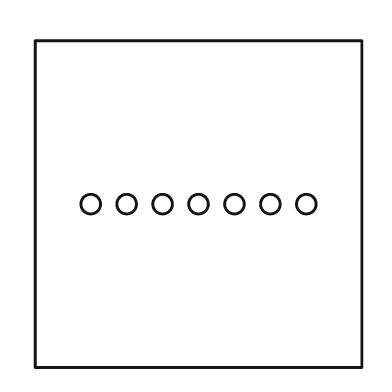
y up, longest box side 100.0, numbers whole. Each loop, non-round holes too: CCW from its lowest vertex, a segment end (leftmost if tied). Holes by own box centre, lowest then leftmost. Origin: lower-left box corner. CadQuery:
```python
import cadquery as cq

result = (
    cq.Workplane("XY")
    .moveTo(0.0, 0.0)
    .lineTo(100.0, 0.0)
    .lineTo(100.0, 100.0)
    .lineTo(0.0, 100.0)
    .close()
    .moveTo(17.0, 50.0)
    .circle(3.0)
    .moveTo(28.0, 50.0)
    .circle(3.0)
    .moveTo(39.0, 50.0)
    .circle(3.0)
    .moveTo(50.0, 50.0)
    .circle(3.0)
    .moveTo(61.0, 50.0)
    .circle(3.0)
    .moveTo(72.0, 50.0)
    .circle(3.0)
    .moveTo(83.0, 50.0)
    .circle(3.0)
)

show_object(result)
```